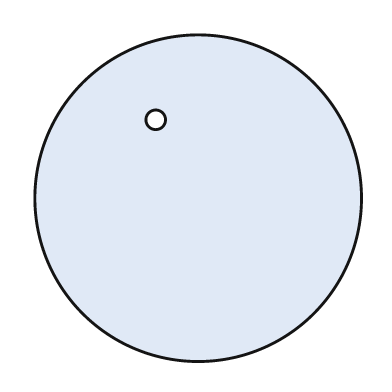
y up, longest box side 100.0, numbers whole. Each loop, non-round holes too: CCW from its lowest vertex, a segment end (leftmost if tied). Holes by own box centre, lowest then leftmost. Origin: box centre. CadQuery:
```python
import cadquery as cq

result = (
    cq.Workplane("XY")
    .moveTo(0.0, 0.0)
    .circle(50.0)
    .moveTo(-13.0, 24.0)
    .circle(3.0)
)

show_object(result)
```